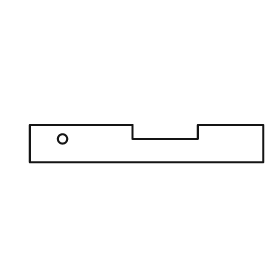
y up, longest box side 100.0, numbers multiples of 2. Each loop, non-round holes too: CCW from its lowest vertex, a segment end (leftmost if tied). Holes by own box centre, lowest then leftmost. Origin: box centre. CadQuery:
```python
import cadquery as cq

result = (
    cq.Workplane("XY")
    .moveTo(-50.0, -8.0)
    .lineTo(50.0, -8.0)
    .lineTo(50.0, 8.0)
    .lineTo(22.0, 8.0)
    .lineTo(22.0, 2.0)
    .lineTo(-6.0, 2.0)
    .lineTo(-6.0, 8.0)
    .lineTo(-50.0, 8.0)
    .close()
    .moveTo(-36.0, 2.0)
    .circle(2.0)
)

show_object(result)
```